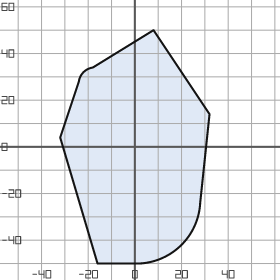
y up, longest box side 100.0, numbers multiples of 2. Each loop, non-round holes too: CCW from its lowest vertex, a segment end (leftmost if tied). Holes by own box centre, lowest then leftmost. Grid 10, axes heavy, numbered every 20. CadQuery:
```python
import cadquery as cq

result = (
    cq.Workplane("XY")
    .moveTo(-16.0, -50.0)
    .lineTo(2.0, -50.0)
    .threePointArc((20.0, -42.0), (28.0, -24.0))
    .lineTo(32.0, 14.0)
    .lineTo(8.0, 50.0)
    .lineTo(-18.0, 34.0)
    .threePointArc((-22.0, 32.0), (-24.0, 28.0))
    .lineTo(-32.0, 4.0)
    .close()
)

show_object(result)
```